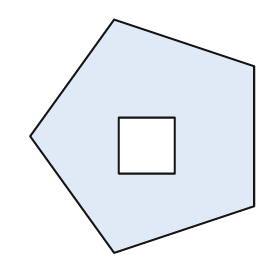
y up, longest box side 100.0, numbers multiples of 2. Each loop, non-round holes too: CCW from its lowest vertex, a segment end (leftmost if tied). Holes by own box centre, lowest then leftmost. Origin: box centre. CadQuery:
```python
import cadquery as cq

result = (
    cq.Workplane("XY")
    .moveTo(-12.0, -50.0)
    .lineTo(48.0, -30.0)
    .lineTo(48.0, 30.0)
    .lineTo(-12.0, 50.0)
    .lineTo(-48.0, 0.0)
    .close()
    .moveTo(-10.0, -16.0)
    .lineTo(14.0, -16.0)
    .lineTo(14.0, 8.0)
    .lineTo(-10.0, 8.0)
    .close()
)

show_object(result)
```